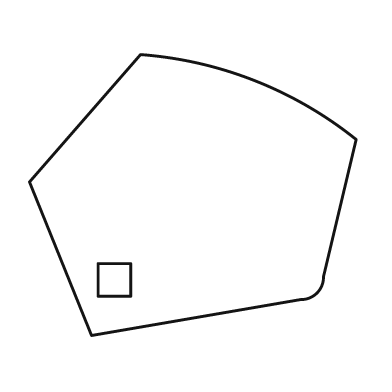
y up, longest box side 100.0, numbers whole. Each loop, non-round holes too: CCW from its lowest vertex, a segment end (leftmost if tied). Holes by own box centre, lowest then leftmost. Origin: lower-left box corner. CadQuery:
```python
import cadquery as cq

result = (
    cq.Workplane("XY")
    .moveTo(19.0, 0.0)
    .lineTo(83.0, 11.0)
    .threePointArc((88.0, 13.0), (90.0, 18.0))
    .lineTo(100.0, 60.0)
    .threePointArc((69.0, 78.0), (34.0, 86.0))
    .lineTo(0.0, 47.0)
    .close()
    .moveTo(21.0, 12.0)
    .lineTo(31.0, 12.0)
    .lineTo(31.0, 22.0)
    .lineTo(21.0, 22.0)
    .close()
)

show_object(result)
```